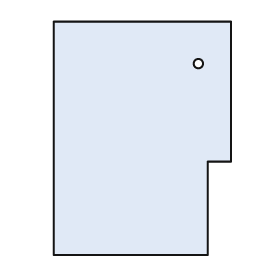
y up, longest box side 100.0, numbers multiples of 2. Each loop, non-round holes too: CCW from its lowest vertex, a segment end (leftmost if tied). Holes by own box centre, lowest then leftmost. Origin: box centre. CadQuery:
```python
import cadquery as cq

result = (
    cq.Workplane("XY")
    .moveTo(-38.0, -50.0)
    .lineTo(28.0, -50.0)
    .lineTo(28.0, -10.0)
    .lineTo(38.0, -10.0)
    .lineTo(38.0, 50.0)
    .lineTo(-38.0, 50.0)
    .close()
    .moveTo(24.0, 32.0)
    .circle(2.0)
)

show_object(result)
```